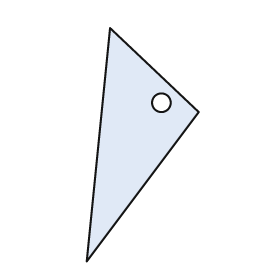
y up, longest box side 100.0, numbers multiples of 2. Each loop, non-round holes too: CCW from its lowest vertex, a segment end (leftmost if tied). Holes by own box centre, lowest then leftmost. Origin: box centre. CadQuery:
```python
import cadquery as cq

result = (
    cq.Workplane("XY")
    .moveTo(-24.0, -50.0)
    .lineTo(24.0, 14.0)
    .lineTo(-14.0, 50.0)
    .close()
    .moveTo(8.0, 18.0)
    .circle(4.0)
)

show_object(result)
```